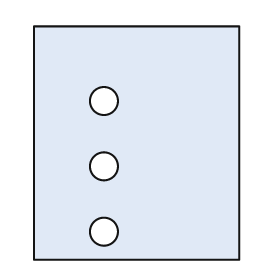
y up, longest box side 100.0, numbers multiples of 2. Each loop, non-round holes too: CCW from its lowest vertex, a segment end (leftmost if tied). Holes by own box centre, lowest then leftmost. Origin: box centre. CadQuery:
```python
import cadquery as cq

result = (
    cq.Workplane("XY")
    .moveTo(-44.0, -50.0)
    .lineTo(44.0, -50.0)
    .lineTo(44.0, 50.0)
    .lineTo(-44.0, 50.0)
    .close()
    .moveTo(-14.0, -38.0)
    .circle(6.0)
    .moveTo(-14.0, -10.0)
    .circle(6.0)
    .moveTo(-14.0, 18.0)
    .circle(6.0)
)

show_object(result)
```